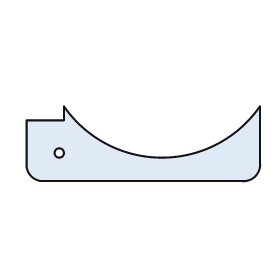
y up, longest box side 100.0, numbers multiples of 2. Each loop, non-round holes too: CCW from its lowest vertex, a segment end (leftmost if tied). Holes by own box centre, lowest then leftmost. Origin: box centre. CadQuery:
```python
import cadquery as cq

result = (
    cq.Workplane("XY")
    .moveTo(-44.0, -16.0)
    .lineTo(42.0, -16.0)
    .threePointArc((48.0, -14.0), (50.0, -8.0))
    .lineTo(50.0, 16.0)
    .threePointArc((8.0, -6.0), (-34.0, 16.0))
    .lineTo(-34.0, 10.0)
    .lineTo(-50.0, 10.0)
    .lineTo(-50.0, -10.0)
    .threePointArc((-48.0, -14.0), (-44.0, -16.0))
    .close()
    .moveTo(-36.0, -4.0)
    .circle(2.0)
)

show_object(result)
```